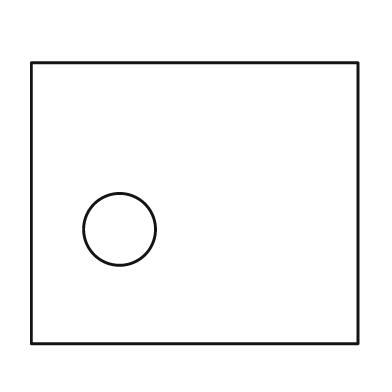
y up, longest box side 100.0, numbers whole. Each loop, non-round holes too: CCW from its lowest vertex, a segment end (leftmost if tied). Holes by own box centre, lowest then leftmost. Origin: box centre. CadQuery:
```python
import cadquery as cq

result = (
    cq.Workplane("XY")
    .moveTo(-50.0, -43.0)
    .lineTo(50.0, -43.0)
    .lineTo(50.0, 43.0)
    .lineTo(-50.0, 43.0)
    .close()
    .moveTo(-23.0, -8.0)
    .circle(11.0)
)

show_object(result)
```